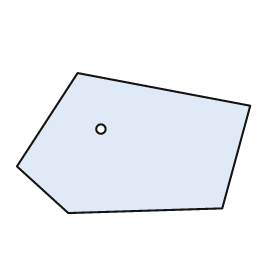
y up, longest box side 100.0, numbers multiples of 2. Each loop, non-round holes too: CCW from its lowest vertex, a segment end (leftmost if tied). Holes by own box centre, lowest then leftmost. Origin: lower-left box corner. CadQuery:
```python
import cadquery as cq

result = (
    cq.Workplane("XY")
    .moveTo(22.0, 0.0)
    .lineTo(88.0, 2.0)
    .lineTo(100.0, 46.0)
    .lineTo(26.0, 60.0)
    .lineTo(0.0, 20.0)
    .close()
    .moveTo(36.0, 36.0)
    .circle(2.0)
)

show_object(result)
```